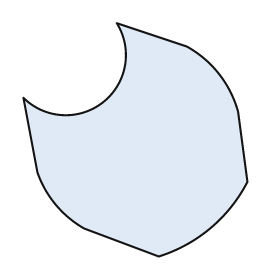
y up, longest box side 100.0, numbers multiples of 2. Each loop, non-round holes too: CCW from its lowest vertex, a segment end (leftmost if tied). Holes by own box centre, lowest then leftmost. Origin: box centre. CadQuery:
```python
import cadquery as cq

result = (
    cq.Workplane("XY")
    .moveTo(10.0, -50.0)
    .threePointArc((32.0, -38.0), (48.0, -18.0))
    .lineTo(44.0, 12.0)
    .threePointArc((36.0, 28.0), (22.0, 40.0))
    .lineTo(-8.0, 50.0)
    .threePointArc((-14.0, 16.0), (-48.0, 18.0))
    .lineTo(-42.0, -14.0)
    .threePointArc((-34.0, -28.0), (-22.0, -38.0))
    .close()
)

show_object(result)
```